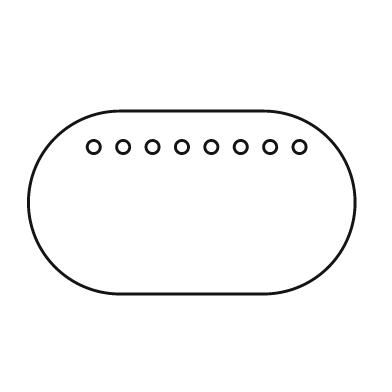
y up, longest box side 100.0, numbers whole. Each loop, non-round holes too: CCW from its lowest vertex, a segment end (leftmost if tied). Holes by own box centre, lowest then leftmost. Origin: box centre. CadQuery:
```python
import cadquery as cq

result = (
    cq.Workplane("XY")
    .moveTo(-22.0, -28.0)
    .lineTo(22.0, -28.0)
    .threePointArc((50.0, 0.0), (22.0, 28.0))
    .lineTo(-22.0, 28.0)
    .threePointArc((-50.0, 0.0), (-22.0, -28.0))
    .close()
    .moveTo(-30.0, 17.0)
    .circle(2.0)
    .moveTo(-21.0, 17.0)
    .circle(2.0)
    .moveTo(-12.0, 17.0)
    .circle(2.0)
    .moveTo(-3.0, 17.0)
    .circle(2.0)
    .moveTo(6.0, 17.0)
    .circle(2.0)
    .moveTo(15.0, 17.0)
    .circle(2.0)
    .moveTo(24.0, 17.0)
    .circle(2.0)
    .moveTo(33.0, 17.0)
    .circle(2.0)
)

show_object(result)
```